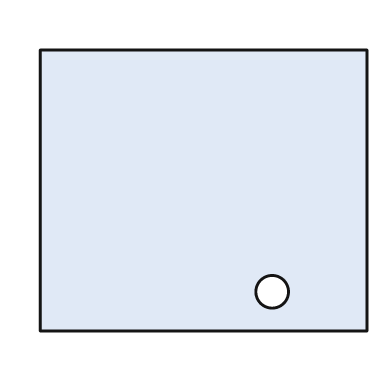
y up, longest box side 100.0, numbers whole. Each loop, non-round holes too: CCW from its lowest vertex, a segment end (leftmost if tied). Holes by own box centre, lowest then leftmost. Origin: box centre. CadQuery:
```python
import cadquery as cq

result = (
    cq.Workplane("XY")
    .moveTo(-50.0, -43.0)
    .lineTo(50.0, -43.0)
    .lineTo(50.0, 43.0)
    .lineTo(-50.0, 43.0)
    .close()
    .moveTo(21.0, -31.0)
    .circle(5.0)
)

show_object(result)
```